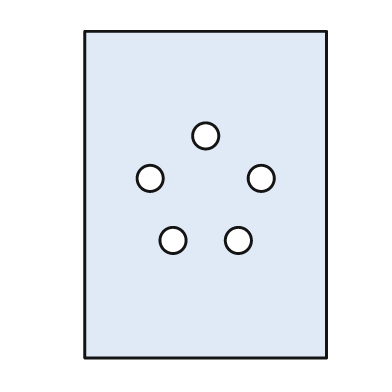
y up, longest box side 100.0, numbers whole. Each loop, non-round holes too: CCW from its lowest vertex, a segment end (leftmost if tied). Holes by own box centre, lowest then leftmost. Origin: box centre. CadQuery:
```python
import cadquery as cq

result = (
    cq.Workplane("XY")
    .moveTo(-37.0, -50.0)
    .lineTo(37.0, -50.0)
    .lineTo(37.0, 50.0)
    .lineTo(-37.0, 50.0)
    .close()
    .moveTo(-10.0, -14.0)
    .circle(4.0)
    .moveTo(10.0, -14.0)
    .circle(4.0)
    .moveTo(-17.0, 5.0)
    .circle(4.0)
    .moveTo(17.0, 5.0)
    .circle(4.0)
    .moveTo(0.0, 18.0)
    .circle(4.0)
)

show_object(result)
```